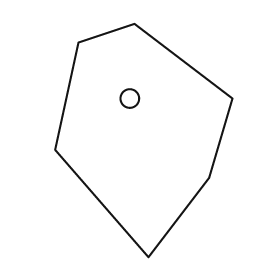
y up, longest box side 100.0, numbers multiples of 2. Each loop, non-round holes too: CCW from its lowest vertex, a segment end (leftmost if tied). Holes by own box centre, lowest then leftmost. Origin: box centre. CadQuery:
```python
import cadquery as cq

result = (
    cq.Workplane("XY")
    .moveTo(2.0, -50.0)
    .lineTo(28.0, -16.0)
    .lineTo(38.0, 18.0)
    .lineTo(-4.0, 50.0)
    .lineTo(-28.0, 42.0)
    .lineTo(-38.0, -4.0)
    .close()
    .moveTo(-6.0, 18.0)
    .circle(4.0)
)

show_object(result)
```